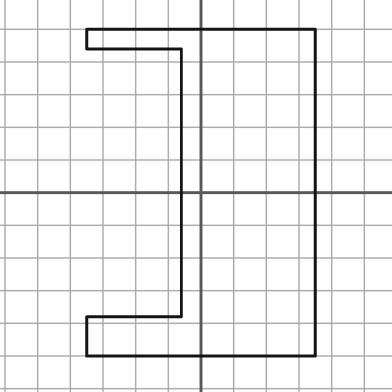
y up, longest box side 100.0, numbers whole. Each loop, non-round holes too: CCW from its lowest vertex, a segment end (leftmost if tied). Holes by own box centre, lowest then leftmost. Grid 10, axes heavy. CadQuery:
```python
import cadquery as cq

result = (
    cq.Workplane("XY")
    .moveTo(-35.0, -50.0)
    .lineTo(35.0, -50.0)
    .lineTo(35.0, 50.0)
    .lineTo(-35.0, 50.0)
    .lineTo(-35.0, 44.0)
    .lineTo(-6.0, 44.0)
    .lineTo(-6.0, -38.0)
    .lineTo(-35.0, -38.0)
    .close()
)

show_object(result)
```